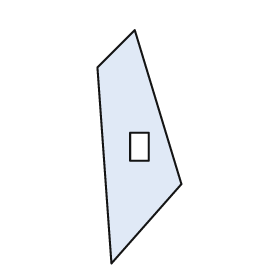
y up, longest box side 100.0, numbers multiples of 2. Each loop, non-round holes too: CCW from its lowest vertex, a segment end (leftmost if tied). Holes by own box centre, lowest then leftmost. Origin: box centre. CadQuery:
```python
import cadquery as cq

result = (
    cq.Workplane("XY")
    .moveTo(-12.0, -50.0)
    .lineTo(18.0, -16.0)
    .lineTo(-2.0, 50.0)
    .lineTo(-18.0, 34.0)
    .close()
    .moveTo(-4.0, -6.0)
    .lineTo(4.0, -6.0)
    .lineTo(4.0, 6.0)
    .lineTo(-4.0, 6.0)
    .close()
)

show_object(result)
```